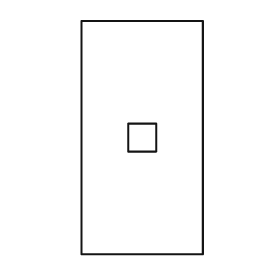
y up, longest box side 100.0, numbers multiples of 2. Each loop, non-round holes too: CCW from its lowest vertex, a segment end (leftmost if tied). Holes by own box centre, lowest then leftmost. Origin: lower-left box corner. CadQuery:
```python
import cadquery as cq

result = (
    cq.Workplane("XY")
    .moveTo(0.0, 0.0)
    .lineTo(52.0, 0.0)
    .lineTo(52.0, 100.0)
    .lineTo(0.0, 100.0)
    .close()
    .moveTo(20.0, 44.0)
    .lineTo(32.0, 44.0)
    .lineTo(32.0, 56.0)
    .lineTo(20.0, 56.0)
    .close()
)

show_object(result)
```